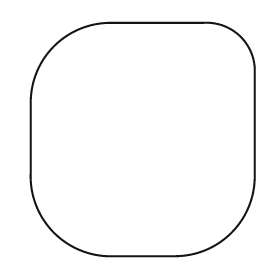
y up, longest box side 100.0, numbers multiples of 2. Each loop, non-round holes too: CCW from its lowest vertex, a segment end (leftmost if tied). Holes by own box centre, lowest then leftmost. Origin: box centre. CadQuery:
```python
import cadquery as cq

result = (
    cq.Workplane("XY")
    .moveTo(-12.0, -50.0)
    .lineTo(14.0, -50.0)
    .threePointArc((38.0, -40.0), (48.0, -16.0))
    .lineTo(48.0, 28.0)
    .threePointArc((42.0, 44.0), (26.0, 50.0))
    .lineTo(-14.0, 50.0)
    .threePointArc((-38.0, 40.0), (-48.0, 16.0))
    .lineTo(-48.0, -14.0)
    .threePointArc((-38.0, -40.0), (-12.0, -50.0))
    .close()
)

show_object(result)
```